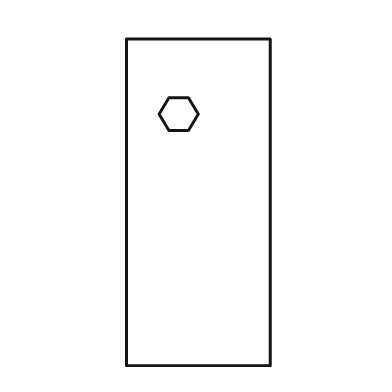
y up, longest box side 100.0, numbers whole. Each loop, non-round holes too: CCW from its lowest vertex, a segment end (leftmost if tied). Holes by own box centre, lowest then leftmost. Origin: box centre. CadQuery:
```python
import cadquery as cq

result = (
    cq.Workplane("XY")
    .moveTo(-22.0, -50.0)
    .lineTo(22.0, -50.0)
    .lineTo(22.0, 50.0)
    .lineTo(-22.0, 50.0)
    .close()
    .moveTo(-9.0, 22.0)
    .lineTo(-3.0, 22.0)
    .lineTo(0.0, 27.0)
    .lineTo(-3.0, 32.0)
    .lineTo(-9.0, 32.0)
    .lineTo(-12.0, 27.0)
    .close()
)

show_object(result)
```